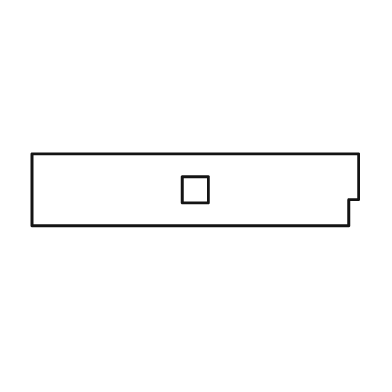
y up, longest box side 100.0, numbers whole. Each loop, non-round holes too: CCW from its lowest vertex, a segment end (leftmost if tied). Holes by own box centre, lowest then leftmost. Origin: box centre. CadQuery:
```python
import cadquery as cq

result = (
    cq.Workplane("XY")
    .moveTo(-50.0, -11.0)
    .lineTo(47.0, -11.0)
    .lineTo(47.0, -3.0)
    .lineTo(50.0, -3.0)
    .lineTo(50.0, 11.0)
    .lineTo(-50.0, 11.0)
    .close()
    .moveTo(-4.0, -4.0)
    .lineTo(4.0, -4.0)
    .lineTo(4.0, 4.0)
    .lineTo(-4.0, 4.0)
    .close()
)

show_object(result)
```